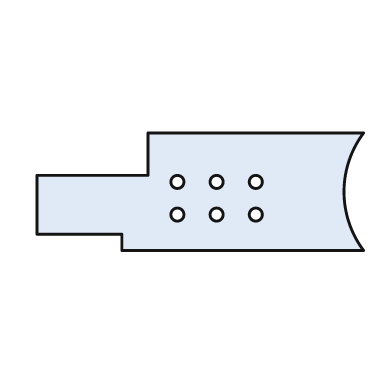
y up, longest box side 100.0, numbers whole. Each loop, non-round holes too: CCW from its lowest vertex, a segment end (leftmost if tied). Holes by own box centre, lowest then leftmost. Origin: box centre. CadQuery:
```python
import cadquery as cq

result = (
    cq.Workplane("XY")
    .moveTo(-24.0, -18.0)
    .lineTo(50.0, -18.0)
    .threePointArc((44.0, 0.0), (50.0, 18.0))
    .lineTo(-16.0, 18.0)
    .lineTo(-16.0, 5.0)
    .lineTo(-50.0, 5.0)
    .lineTo(-50.0, -13.0)
    .lineTo(-24.0, -13.0)
    .close()
    .moveTo(-7.0, -7.0)
    .circle(2.0)
    .moveTo(5.0, -7.0)
    .circle(2.0)
    .moveTo(17.0, -7.0)
    .circle(2.0)
    .moveTo(-7.0, 3.0)
    .circle(2.0)
    .moveTo(5.0, 3.0)
    .circle(2.0)
    .moveTo(17.0, 3.0)
    .circle(2.0)
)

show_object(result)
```